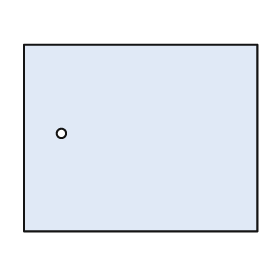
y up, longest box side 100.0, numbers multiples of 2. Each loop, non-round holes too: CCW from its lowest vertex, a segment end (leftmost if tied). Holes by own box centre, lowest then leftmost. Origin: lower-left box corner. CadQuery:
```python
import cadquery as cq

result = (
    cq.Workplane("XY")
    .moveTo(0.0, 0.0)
    .lineTo(100.0, 0.0)
    .lineTo(100.0, 80.0)
    .lineTo(0.0, 80.0)
    .close()
    .moveTo(16.0, 42.0)
    .circle(2.0)
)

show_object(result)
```